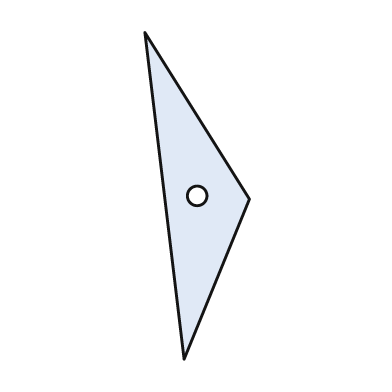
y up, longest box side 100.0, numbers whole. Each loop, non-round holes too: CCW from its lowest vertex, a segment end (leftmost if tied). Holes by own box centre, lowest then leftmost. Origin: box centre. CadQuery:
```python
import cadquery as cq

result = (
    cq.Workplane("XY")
    .moveTo(-4.0, -50.0)
    .lineTo(16.0, -1.0)
    .lineTo(-16.0, 50.0)
    .close()
    .moveTo(0.0, 0.0)
    .circle(3.0)
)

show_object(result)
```